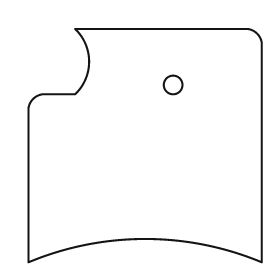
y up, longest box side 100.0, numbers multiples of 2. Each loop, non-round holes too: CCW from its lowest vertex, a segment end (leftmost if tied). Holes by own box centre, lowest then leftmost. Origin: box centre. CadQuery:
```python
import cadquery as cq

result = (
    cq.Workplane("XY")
    .moveTo(-50.0, -50.0)
    .threePointArc((0.0, -40.0), (50.0, -50.0))
    .lineTo(50.0, 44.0)
    .threePointArc((48.0, 48.0), (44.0, 50.0))
    .lineTo(-30.0, 50.0)
    .threePointArc((-24.0, 36.0), (-30.0, 22.0))
    .lineTo(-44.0, 22.0)
    .threePointArc((-48.0, 20.0), (-50.0, 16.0))
    .close()
    .moveTo(12.0, 26.0)
    .circle(4.0)
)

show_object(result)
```